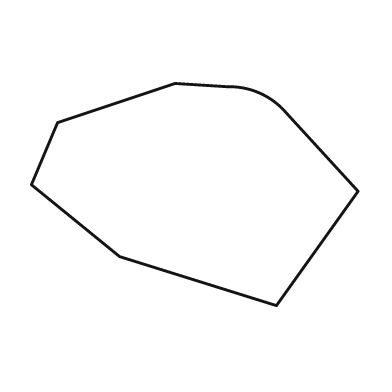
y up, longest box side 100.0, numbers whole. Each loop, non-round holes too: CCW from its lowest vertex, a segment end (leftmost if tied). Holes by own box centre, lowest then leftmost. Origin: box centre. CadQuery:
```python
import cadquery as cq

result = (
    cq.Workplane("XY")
    .moveTo(25.0, -34.0)
    .lineTo(50.0, 1.0)
    .lineTo(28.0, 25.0)
    .threePointArc((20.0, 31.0), (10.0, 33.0))
    .lineTo(-6.0, 34.0)
    .lineTo(-42.0, 22.0)
    .lineTo(-50.0, 3.0)
    .lineTo(-23.0, -19.0)
    .close()
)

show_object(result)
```